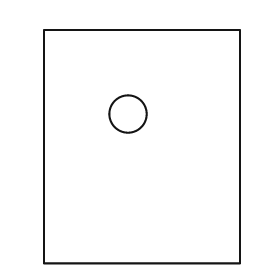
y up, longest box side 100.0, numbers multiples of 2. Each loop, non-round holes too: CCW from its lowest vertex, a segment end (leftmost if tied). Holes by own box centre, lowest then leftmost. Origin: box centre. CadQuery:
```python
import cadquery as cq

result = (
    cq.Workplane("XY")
    .moveTo(-42.0, -50.0)
    .lineTo(42.0, -50.0)
    .lineTo(42.0, 50.0)
    .lineTo(-42.0, 50.0)
    .close()
    .moveTo(-6.0, 14.0)
    .circle(8.0)
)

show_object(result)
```